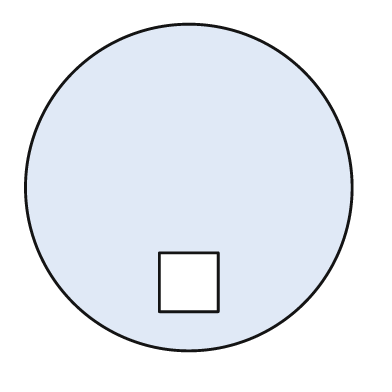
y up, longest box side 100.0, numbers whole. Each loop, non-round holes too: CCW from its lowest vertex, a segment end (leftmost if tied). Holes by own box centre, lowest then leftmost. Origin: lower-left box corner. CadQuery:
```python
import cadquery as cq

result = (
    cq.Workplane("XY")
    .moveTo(50.0, 50.0)
    .circle(50.0)
    .moveTo(41.0, 12.0)
    .lineTo(59.0, 12.0)
    .lineTo(59.0, 30.0)
    .lineTo(41.0, 30.0)
    .close()
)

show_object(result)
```